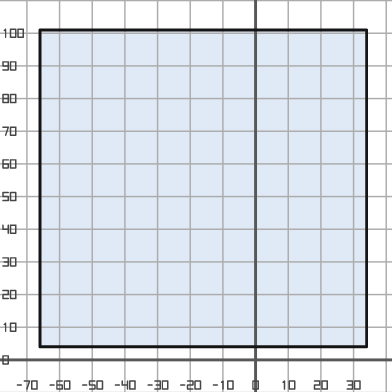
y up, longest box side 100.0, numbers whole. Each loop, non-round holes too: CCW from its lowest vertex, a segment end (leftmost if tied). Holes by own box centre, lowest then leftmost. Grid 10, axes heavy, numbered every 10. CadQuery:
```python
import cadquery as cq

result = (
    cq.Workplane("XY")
    .moveTo(-66.0, 4.0)
    .lineTo(34.0, 4.0)
    .lineTo(34.0, 101.0)
    .lineTo(-66.0, 101.0)
    .close()
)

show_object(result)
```